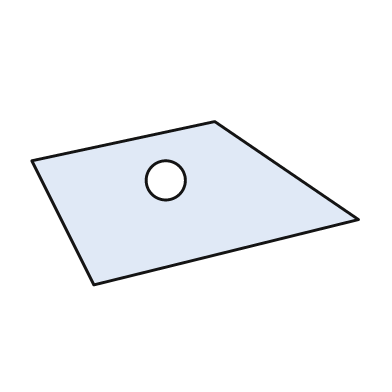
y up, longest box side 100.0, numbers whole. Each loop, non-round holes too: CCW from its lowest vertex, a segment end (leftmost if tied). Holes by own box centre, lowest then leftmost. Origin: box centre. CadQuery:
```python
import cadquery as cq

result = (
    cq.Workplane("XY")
    .moveTo(-31.0, -25.0)
    .lineTo(50.0, -5.0)
    .lineTo(6.0, 25.0)
    .lineTo(-50.0, 13.0)
    .close()
    .moveTo(-9.0, 7.0)
    .circle(6.0)
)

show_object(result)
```